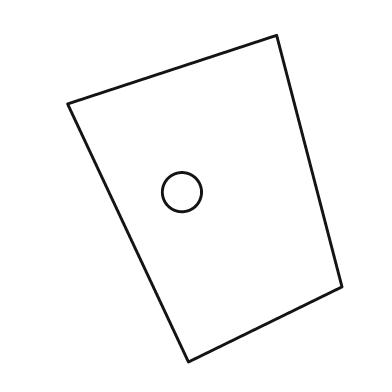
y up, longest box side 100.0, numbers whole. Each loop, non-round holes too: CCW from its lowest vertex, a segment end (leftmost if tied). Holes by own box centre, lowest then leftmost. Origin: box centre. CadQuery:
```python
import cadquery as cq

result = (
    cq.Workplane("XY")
    .moveTo(-5.0, -50.0)
    .lineTo(42.0, -27.0)
    .lineTo(22.0, 50.0)
    .lineTo(-42.0, 29.0)
    .close()
    .moveTo(-7.0, 2.0)
    .circle(6.0)
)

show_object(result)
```